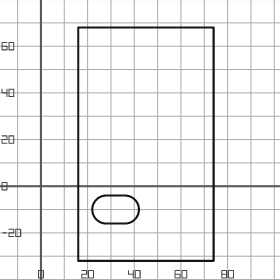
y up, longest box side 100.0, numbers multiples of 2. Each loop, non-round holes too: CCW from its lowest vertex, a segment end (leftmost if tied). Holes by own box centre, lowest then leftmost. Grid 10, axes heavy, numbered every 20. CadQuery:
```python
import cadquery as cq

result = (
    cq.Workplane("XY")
    .moveTo(16.0, -32.0)
    .lineTo(74.0, -32.0)
    .lineTo(74.0, 68.0)
    .lineTo(16.0, 68.0)
    .close()
    .moveTo(28.0, -16.0)
    .lineTo(36.0, -16.0)
    .threePointArc((42.0, -10.0), (36.0, -4.0))
    .lineTo(28.0, -4.0)
    .threePointArc((22.0, -10.0), (28.0, -16.0))
    .close()
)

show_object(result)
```